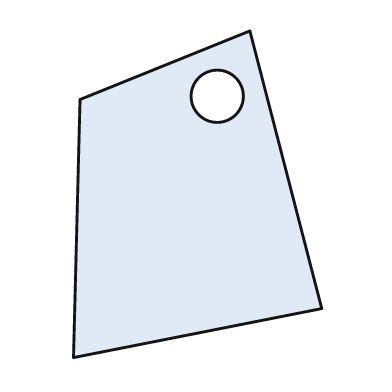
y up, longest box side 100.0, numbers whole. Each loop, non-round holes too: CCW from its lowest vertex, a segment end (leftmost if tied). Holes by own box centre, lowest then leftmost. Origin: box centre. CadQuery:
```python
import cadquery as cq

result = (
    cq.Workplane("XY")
    .moveTo(-38.0, -50.0)
    .lineTo(38.0, -35.0)
    .lineTo(16.0, 50.0)
    .lineTo(-36.0, 29.0)
    .close()
    .moveTo(6.0, 30.0)
    .circle(8.0)
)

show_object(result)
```